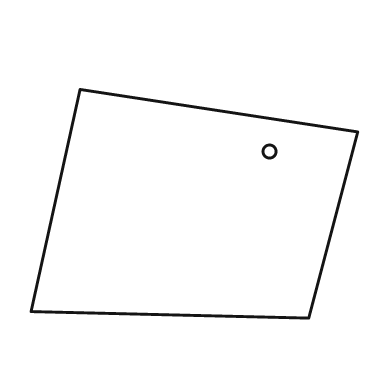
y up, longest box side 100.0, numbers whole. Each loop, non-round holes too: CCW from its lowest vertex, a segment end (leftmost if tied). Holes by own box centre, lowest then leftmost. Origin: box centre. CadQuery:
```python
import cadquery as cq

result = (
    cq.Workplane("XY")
    .moveTo(35.0, -35.0)
    .lineTo(50.0, 22.0)
    .lineTo(-35.0, 35.0)
    .lineTo(-50.0, -33.0)
    .close()
    .moveTo(23.0, 16.0)
    .circle(2.0)
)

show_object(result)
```